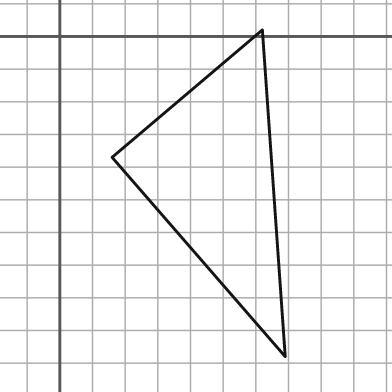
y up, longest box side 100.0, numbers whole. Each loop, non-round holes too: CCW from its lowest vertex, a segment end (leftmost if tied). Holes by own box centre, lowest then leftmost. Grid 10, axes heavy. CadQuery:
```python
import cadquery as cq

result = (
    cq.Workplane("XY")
    .moveTo(69.0, -98.0)
    .lineTo(62.0, 2.0)
    .lineTo(16.0, -37.0)
    .close()
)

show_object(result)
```